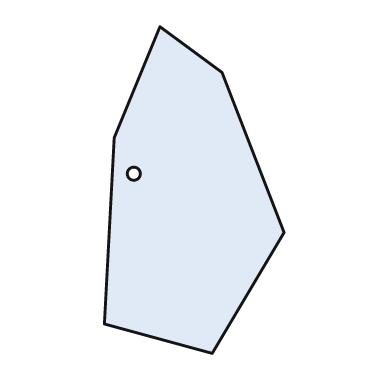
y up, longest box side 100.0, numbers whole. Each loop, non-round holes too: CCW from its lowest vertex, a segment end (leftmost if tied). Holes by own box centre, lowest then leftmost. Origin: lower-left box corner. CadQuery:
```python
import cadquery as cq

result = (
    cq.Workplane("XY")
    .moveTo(33.0, 0.0)
    .lineTo(55.0, 37.0)
    .lineTo(36.0, 86.0)
    .lineTo(17.0, 100.0)
    .lineTo(3.0, 66.0)
    .lineTo(0.0, 9.0)
    .close()
    .moveTo(9.0, 55.0)
    .circle(2.0)
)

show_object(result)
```